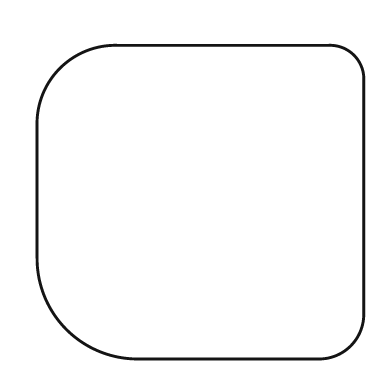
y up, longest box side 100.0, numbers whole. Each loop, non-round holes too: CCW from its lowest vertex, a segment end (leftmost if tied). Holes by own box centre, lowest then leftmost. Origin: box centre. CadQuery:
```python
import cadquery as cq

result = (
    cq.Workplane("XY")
    .moveTo(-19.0, -48.0)
    .lineTo(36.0, -48.0)
    .threePointArc((46.0, -44.0), (50.0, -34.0))
    .lineTo(50.0, 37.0)
    .threePointArc((47.0, 45.0), (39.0, 48.0))
    .lineTo(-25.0, 48.0)
    .threePointArc((-43.0, 41.0), (-50.0, 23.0))
    .lineTo(-50.0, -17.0)
    .threePointArc((-41.0, -39.0), (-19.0, -48.0))
    .close()
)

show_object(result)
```